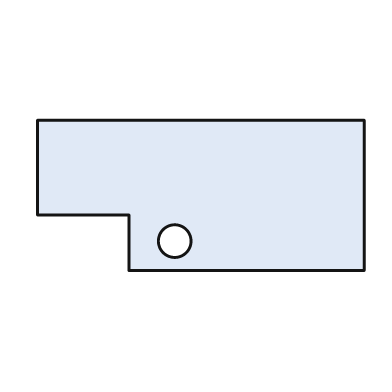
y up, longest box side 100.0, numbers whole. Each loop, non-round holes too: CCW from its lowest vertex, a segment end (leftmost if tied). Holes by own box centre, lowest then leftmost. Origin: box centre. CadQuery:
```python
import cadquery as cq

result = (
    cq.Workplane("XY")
    .moveTo(-22.0, -23.0)
    .lineTo(50.0, -23.0)
    .lineTo(50.0, 23.0)
    .lineTo(-50.0, 23.0)
    .lineTo(-50.0, -6.0)
    .lineTo(-22.0, -6.0)
    .close()
    .moveTo(-8.0, -14.0)
    .circle(5.0)
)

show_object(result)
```